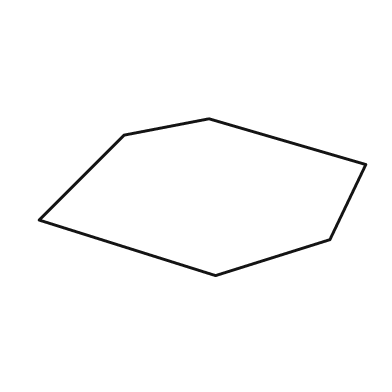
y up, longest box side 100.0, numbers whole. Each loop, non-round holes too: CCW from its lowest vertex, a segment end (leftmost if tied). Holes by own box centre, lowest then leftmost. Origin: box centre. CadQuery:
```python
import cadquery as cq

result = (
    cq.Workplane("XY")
    .moveTo(4.0, -24.0)
    .lineTo(39.0, -13.0)
    .lineTo(50.0, 10.0)
    .lineTo(2.0, 24.0)
    .lineTo(-24.0, 19.0)
    .lineTo(-50.0, -7.0)
    .close()
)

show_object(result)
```